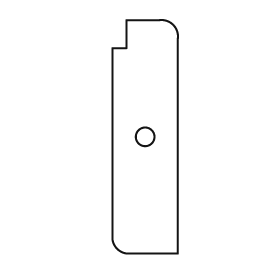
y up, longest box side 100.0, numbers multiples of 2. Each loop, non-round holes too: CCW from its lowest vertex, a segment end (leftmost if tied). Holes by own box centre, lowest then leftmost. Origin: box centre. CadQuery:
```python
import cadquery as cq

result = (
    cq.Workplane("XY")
    .moveTo(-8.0, -50.0)
    .lineTo(14.0, -50.0)
    .lineTo(14.0, 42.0)
    .threePointArc((12.0, 48.0), (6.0, 50.0))
    .lineTo(-8.0, 50.0)
    .lineTo(-8.0, 38.0)
    .lineTo(-14.0, 38.0)
    .lineTo(-14.0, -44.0)
    .threePointArc((-12.0, -48.0), (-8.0, -50.0))
    .close()
    .moveTo(0.0, 0.0)
    .circle(4.0)
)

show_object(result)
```